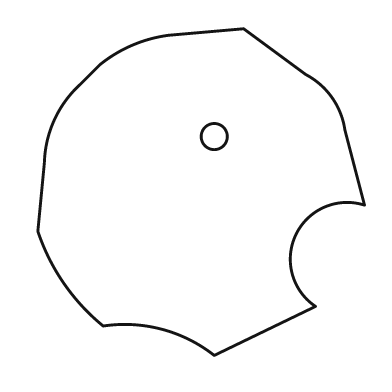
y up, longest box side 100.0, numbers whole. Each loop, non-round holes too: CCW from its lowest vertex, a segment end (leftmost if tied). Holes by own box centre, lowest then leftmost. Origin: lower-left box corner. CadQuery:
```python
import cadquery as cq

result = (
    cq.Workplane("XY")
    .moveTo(54.0, 0.0)
    .lineTo(85.0, 15.0)
    .threePointArc((79.0, 37.0), (100.0, 46.0))
    .lineTo(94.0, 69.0)
    .threePointArc((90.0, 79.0), (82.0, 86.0))
    .lineTo(63.0, 100.0)
    .lineTo(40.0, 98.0)
    .threePointArc((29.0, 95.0), (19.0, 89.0))
    .lineTo(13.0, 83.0)
    .threePointArc((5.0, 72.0), (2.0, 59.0))
    .lineTo(0.0, 38.0)
    .threePointArc((8.0, 22.0), (20.0, 9.0))
    .threePointArc((38.0, 8.0), (54.0, 0.0))
    .close()
    .moveTo(54.0, 67.0)
    .circle(4.0)
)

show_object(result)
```